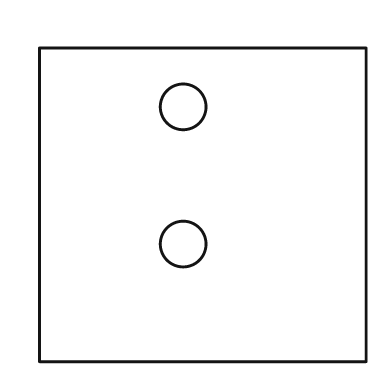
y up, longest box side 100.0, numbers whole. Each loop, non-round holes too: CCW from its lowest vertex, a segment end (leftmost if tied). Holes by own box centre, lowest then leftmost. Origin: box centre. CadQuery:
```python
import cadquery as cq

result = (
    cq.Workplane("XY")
    .moveTo(-50.0, -48.0)
    .lineTo(50.0, -48.0)
    .lineTo(50.0, 48.0)
    .lineTo(-50.0, 48.0)
    .close()
    .moveTo(-6.0, -12.0)
    .circle(7.0)
    .moveTo(-6.0, 30.0)
    .circle(7.0)
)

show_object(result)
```